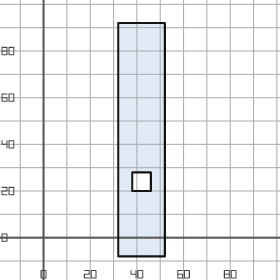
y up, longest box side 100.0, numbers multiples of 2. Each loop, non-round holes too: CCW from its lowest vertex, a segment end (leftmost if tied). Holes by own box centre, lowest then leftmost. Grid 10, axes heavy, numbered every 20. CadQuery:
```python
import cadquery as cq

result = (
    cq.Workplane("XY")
    .moveTo(32.0, -8.0)
    .lineTo(52.0, -8.0)
    .lineTo(52.0, 92.0)
    .lineTo(32.0, 92.0)
    .close()
    .moveTo(38.0, 20.0)
    .lineTo(46.0, 20.0)
    .lineTo(46.0, 28.0)
    .lineTo(38.0, 28.0)
    .close()
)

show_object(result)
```